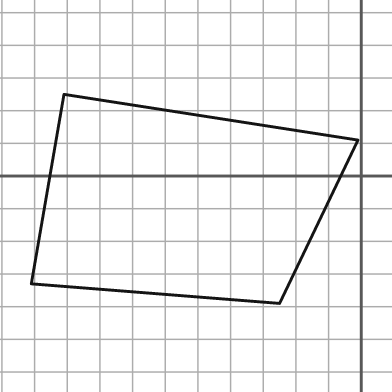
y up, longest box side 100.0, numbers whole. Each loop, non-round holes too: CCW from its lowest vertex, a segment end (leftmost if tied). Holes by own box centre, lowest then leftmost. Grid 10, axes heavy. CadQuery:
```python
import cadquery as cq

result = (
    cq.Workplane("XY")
    .moveTo(-25.0, -39.0)
    .lineTo(-1.0, 11.0)
    .lineTo(-91.0, 25.0)
    .lineTo(-101.0, -33.0)
    .close()
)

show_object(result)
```